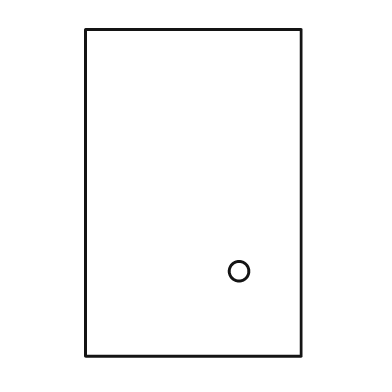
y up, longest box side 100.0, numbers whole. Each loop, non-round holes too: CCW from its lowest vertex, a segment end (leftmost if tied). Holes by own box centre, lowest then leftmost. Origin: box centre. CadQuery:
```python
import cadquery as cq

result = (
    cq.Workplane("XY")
    .moveTo(-33.0, -50.0)
    .lineTo(33.0, -50.0)
    .lineTo(33.0, 50.0)
    .lineTo(-33.0, 50.0)
    .close()
    .moveTo(14.0, -24.0)
    .circle(3.0)
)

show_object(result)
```